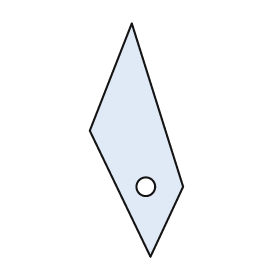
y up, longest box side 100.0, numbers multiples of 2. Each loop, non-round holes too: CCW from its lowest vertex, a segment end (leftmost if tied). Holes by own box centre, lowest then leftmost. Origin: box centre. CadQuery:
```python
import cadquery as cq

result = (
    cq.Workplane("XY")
    .moveTo(6.0, -50.0)
    .lineTo(20.0, -20.0)
    .lineTo(-2.0, 50.0)
    .lineTo(-20.0, 4.0)
    .close()
    .moveTo(4.0, -20.0)
    .circle(4.0)
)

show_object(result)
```